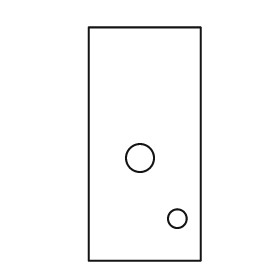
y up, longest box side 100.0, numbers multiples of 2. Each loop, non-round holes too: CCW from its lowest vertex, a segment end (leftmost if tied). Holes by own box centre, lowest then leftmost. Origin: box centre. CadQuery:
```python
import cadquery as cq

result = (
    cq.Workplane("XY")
    .moveTo(-24.0, -50.0)
    .lineTo(24.0, -50.0)
    .lineTo(24.0, 50.0)
    .lineTo(-24.0, 50.0)
    .close()
    .moveTo(14.0, -32.0)
    .circle(4.0)
    .moveTo(-2.0, -6.0)
    .circle(6.0)
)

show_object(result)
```